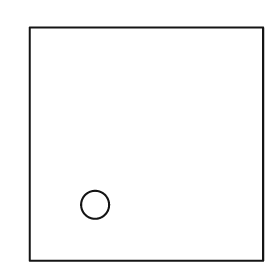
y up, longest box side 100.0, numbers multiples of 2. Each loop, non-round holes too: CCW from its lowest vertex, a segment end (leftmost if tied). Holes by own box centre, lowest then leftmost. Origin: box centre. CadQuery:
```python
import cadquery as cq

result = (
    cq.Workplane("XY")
    .moveTo(-50.0, -50.0)
    .lineTo(50.0, -50.0)
    .lineTo(50.0, 50.0)
    .lineTo(-50.0, 50.0)
    .close()
    .moveTo(-22.0, -26.0)
    .circle(6.0)
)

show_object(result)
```